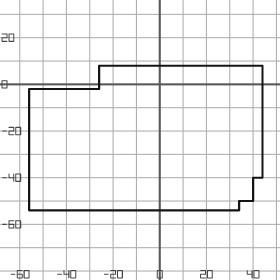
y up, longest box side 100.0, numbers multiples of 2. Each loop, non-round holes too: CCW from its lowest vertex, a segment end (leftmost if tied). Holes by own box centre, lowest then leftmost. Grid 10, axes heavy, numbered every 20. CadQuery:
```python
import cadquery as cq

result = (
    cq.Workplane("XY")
    .moveTo(-56.0, -54.0)
    .lineTo(34.0, -54.0)
    .lineTo(34.0, -50.0)
    .lineTo(40.0, -50.0)
    .lineTo(40.0, -40.0)
    .lineTo(44.0, -40.0)
    .lineTo(44.0, 8.0)
    .lineTo(-26.0, 8.0)
    .lineTo(-26.0, -2.0)
    .lineTo(-56.0, -2.0)
    .close()
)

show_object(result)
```